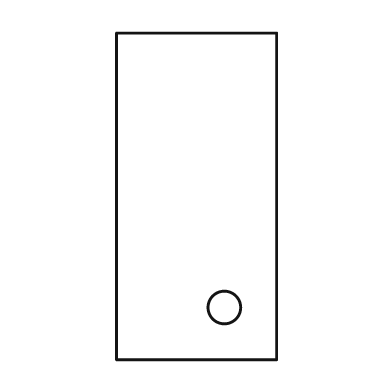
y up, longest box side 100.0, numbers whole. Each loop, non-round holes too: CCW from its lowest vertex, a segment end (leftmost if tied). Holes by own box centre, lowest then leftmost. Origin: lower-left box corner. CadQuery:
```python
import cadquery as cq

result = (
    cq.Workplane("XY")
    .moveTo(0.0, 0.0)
    .lineTo(49.0, 0.0)
    .lineTo(49.0, 100.0)
    .lineTo(0.0, 100.0)
    .close()
    .moveTo(33.0, 16.0)
    .circle(5.0)
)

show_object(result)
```